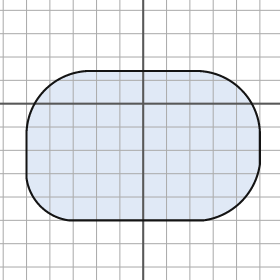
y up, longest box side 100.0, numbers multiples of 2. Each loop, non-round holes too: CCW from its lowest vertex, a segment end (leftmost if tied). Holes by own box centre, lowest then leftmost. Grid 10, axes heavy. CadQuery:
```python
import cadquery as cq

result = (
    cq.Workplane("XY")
    .moveTo(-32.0, -50.0)
    .lineTo(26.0, -50.0)
    .threePointArc((42.0, -42.0), (50.0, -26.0))
    .lineTo(50.0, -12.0)
    .threePointArc((42.0, 6.0), (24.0, 14.0))
    .lineTo(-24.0, 14.0)
    .threePointArc((-42.0, 6.0), (-50.0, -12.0))
    .lineTo(-50.0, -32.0)
    .threePointArc((-44.0, -44.0), (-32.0, -50.0))
    .close()
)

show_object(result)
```